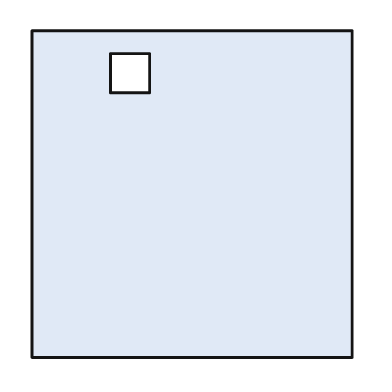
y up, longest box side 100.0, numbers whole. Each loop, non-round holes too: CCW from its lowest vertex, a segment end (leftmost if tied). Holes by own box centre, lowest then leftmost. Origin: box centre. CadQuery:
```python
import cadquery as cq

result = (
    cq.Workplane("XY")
    .moveTo(-49.0, -50.0)
    .lineTo(49.0, -50.0)
    .lineTo(49.0, 50.0)
    .lineTo(-49.0, 50.0)
    .close()
    .moveTo(-25.0, 31.0)
    .lineTo(-13.0, 31.0)
    .lineTo(-13.0, 43.0)
    .lineTo(-25.0, 43.0)
    .close()
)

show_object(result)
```